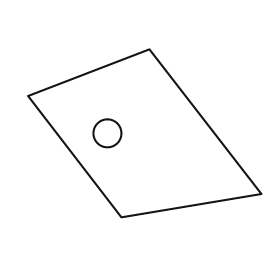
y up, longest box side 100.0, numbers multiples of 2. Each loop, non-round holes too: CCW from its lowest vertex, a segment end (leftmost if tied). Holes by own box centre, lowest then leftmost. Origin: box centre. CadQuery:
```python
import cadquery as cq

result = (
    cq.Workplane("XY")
    .moveTo(-10.0, -36.0)
    .lineTo(50.0, -26.0)
    .lineTo(2.0, 36.0)
    .lineTo(-50.0, 16.0)
    .close()
    .moveTo(-16.0, 0.0)
    .circle(6.0)
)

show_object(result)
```